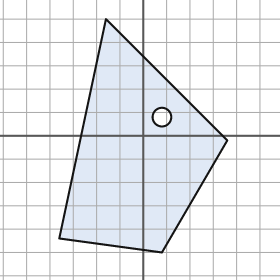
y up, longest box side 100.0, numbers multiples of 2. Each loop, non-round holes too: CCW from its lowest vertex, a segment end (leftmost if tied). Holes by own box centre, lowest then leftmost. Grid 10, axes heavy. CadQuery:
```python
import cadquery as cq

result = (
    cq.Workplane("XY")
    .moveTo(8.0, -50.0)
    .lineTo(36.0, -2.0)
    .lineTo(-16.0, 50.0)
    .lineTo(-36.0, -44.0)
    .close()
    .moveTo(8.0, 8.0)
    .circle(4.0)
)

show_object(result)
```